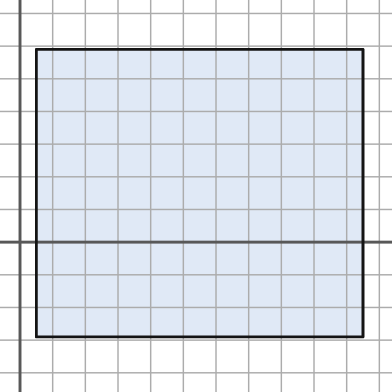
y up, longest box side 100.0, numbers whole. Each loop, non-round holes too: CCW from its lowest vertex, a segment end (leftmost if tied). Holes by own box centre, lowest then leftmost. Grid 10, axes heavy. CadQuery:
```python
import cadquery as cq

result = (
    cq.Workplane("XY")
    .moveTo(5.0, -29.0)
    .lineTo(105.0, -29.0)
    .lineTo(105.0, 59.0)
    .lineTo(5.0, 59.0)
    .close()
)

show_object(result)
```